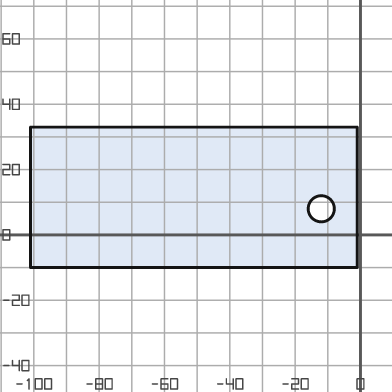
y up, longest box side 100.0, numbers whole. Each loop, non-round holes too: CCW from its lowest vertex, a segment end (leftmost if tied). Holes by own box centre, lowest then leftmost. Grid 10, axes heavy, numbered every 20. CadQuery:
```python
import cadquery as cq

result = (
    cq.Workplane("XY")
    .moveTo(-101.0, -10.0)
    .lineTo(-1.0, -10.0)
    .lineTo(-1.0, 33.0)
    .lineTo(-101.0, 33.0)
    .close()
    .moveTo(-12.0, 8.0)
    .circle(4.0)
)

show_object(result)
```